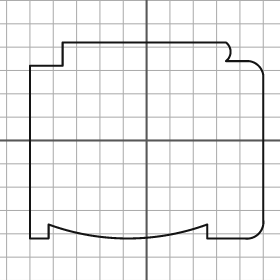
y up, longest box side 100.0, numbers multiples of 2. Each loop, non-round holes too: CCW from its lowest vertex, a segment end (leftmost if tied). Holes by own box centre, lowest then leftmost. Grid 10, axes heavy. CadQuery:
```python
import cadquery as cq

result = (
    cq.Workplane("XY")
    .moveTo(-50.0, -42.0)
    .lineTo(-42.0, -42.0)
    .lineTo(-42.0, -36.0)
    .threePointArc((-8.0, -42.0), (26.0, -36.0))
    .lineTo(26.0, -42.0)
    .lineTo(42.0, -42.0)
    .threePointArc((48.0, -40.0), (50.0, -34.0))
    .lineTo(50.0, 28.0)
    .threePointArc((48.0, 32.0), (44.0, 34.0))
    .lineTo(34.0, 34.0)
    .threePointArc((36.0, 38.0), (34.0, 42.0))
    .lineTo(-36.0, 42.0)
    .lineTo(-36.0, 32.0)
    .lineTo(-50.0, 32.0)
    .close()
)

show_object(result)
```